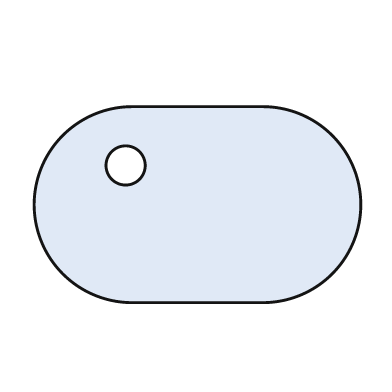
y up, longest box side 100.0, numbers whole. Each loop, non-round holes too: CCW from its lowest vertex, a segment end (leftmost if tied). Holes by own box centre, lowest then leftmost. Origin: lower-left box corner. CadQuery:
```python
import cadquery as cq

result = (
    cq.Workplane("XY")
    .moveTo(30.0, 0.0)
    .lineTo(70.0, 0.0)
    .threePointArc((100.0, 30.0), (70.0, 60.0))
    .lineTo(30.0, 60.0)
    .threePointArc((0.0, 30.0), (30.0, 0.0))
    .close()
    .moveTo(28.0, 42.0)
    .circle(6.0)
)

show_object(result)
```